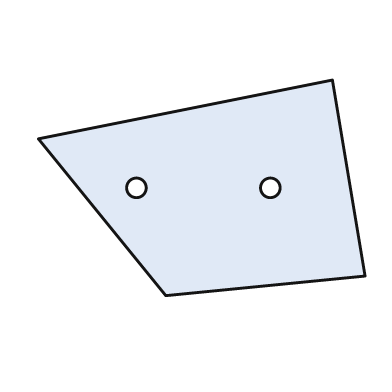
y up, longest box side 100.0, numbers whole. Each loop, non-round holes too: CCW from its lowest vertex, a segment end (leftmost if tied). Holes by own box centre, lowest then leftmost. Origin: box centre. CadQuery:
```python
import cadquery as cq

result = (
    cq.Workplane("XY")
    .moveTo(-11.0, -33.0)
    .lineTo(50.0, -27.0)
    .lineTo(40.0, 33.0)
    .lineTo(-50.0, 15.0)
    .close()
    .moveTo(-20.0, 0.0)
    .circle(3.0)
    .moveTo(21.0, 0.0)
    .circle(3.0)
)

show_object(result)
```